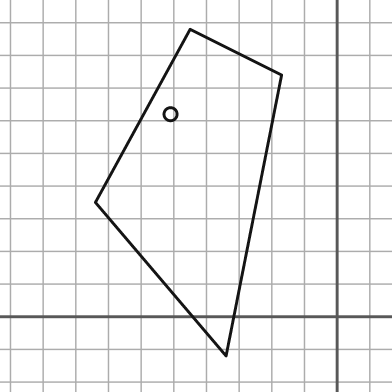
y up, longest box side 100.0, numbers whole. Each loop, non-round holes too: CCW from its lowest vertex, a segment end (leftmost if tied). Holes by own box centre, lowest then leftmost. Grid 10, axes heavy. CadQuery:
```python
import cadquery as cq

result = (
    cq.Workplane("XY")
    .moveTo(-34.0, -12.0)
    .lineTo(-17.0, 74.0)
    .lineTo(-45.0, 88.0)
    .lineTo(-74.0, 35.0)
    .close()
    .moveTo(-51.0, 62.0)
    .circle(2.0)
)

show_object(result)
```